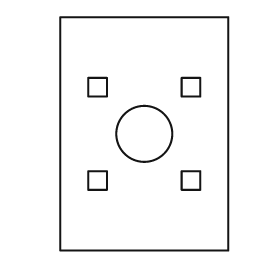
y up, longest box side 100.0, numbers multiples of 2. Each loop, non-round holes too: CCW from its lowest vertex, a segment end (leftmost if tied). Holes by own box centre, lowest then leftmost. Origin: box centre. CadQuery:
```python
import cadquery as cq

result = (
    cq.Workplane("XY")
    .moveTo(-36.0, -50.0)
    .lineTo(36.0, -50.0)
    .lineTo(36.0, 50.0)
    .lineTo(-36.0, 50.0)
    .close()
    .moveTo(-24.0, -24.0)
    .lineTo(-16.0, -24.0)
    .lineTo(-16.0, -16.0)
    .lineTo(-24.0, -16.0)
    .close()
    .moveTo(16.0, -24.0)
    .lineTo(24.0, -24.0)
    .lineTo(24.0, -16.0)
    .lineTo(16.0, -16.0)
    .close()
    .moveTo(0.0, 0.0)
    .circle(12.0)
    .moveTo(-24.0, 16.0)
    .lineTo(-16.0, 16.0)
    .lineTo(-16.0, 24.0)
    .lineTo(-24.0, 24.0)
    .close()
    .moveTo(16.0, 16.0)
    .lineTo(24.0, 16.0)
    .lineTo(24.0, 24.0)
    .lineTo(16.0, 24.0)
    .close()
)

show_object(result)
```